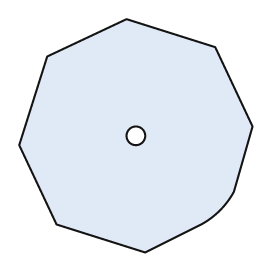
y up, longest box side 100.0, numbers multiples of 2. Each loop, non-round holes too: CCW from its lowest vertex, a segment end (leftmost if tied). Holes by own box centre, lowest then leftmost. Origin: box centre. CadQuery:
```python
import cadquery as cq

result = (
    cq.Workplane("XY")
    .moveTo(4.0, -50.0)
    .lineTo(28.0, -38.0)
    .threePointArc((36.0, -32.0), (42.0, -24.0))
    .lineTo(50.0, 4.0)
    .lineTo(34.0, 38.0)
    .lineTo(-4.0, 50.0)
    .lineTo(-38.0, 34.0)
    .lineTo(-50.0, -4.0)
    .lineTo(-34.0, -38.0)
    .close()
    .moveTo(0.0, 0.0)
    .circle(4.0)
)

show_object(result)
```